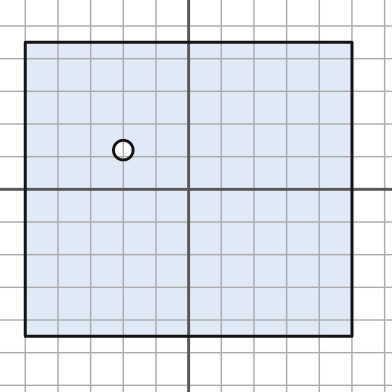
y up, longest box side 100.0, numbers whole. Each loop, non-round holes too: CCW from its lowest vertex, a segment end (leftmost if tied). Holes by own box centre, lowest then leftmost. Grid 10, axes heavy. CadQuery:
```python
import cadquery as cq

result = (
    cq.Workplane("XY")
    .moveTo(-50.0, -45.0)
    .lineTo(50.0, -45.0)
    .lineTo(50.0, 45.0)
    .lineTo(-50.0, 45.0)
    .close()
    .moveTo(-20.0, 12.0)
    .circle(3.0)
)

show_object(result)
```